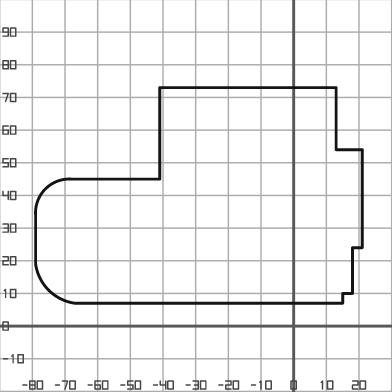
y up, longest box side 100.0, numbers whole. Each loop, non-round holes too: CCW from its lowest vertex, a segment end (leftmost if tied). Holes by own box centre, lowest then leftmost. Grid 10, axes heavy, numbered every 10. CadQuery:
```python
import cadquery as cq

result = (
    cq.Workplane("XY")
    .moveTo(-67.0, 7.0)
    .lineTo(15.0, 7.0)
    .lineTo(15.0, 10.0)
    .lineTo(18.0, 10.0)
    .lineTo(18.0, 24.0)
    .lineTo(21.0, 24.0)
    .lineTo(21.0, 54.0)
    .lineTo(13.0, 54.0)
    .lineTo(13.0, 73.0)
    .lineTo(-41.0, 73.0)
    .lineTo(-41.0, 45.0)
    .lineTo(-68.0, 45.0)
    .threePointArc((-76.0, 42.0), (-79.0, 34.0))
    .lineTo(-79.0, 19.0)
    .threePointArc((-75.0, 11.0), (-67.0, 7.0))
    .close()
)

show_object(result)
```